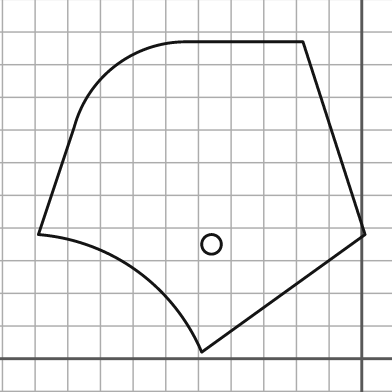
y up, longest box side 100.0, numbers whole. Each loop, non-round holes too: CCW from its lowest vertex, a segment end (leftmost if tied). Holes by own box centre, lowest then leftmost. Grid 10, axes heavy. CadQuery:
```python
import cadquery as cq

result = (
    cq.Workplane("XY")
    .moveTo(-49.0, 2.0)
    .lineTo(1.0, 38.0)
    .lineTo(-18.0, 97.0)
    .lineTo(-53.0, 97.0)
    .threePointArc((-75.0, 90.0), (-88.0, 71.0))
    .lineTo(-99.0, 38.0)
    .threePointArc((-69.0, 27.0), (-49.0, 2.0))
    .close()
    .moveTo(-46.0, 35.0)
    .circle(3.0)
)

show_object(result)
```